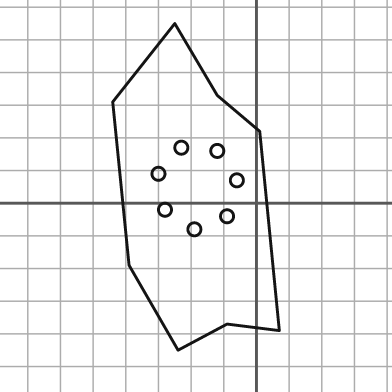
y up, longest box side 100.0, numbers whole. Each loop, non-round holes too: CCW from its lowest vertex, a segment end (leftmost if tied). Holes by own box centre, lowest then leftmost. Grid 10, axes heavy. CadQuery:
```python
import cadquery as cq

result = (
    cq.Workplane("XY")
    .moveTo(-24.0, -45.0)
    .lineTo(-9.0, -37.0)
    .lineTo(7.0, -39.0)
    .lineTo(1.0, 22.0)
    .lineTo(-12.0, 33.0)
    .lineTo(-25.0, 55.0)
    .lineTo(-44.0, 31.0)
    .lineTo(-39.0, -19.0)
    .close()
    .moveTo(-19.0, -8.0)
    .circle(2.0)
    .moveTo(-9.0, -4.0)
    .circle(2.0)
    .moveTo(-28.0, -2.0)
    .circle(2.0)
    .moveTo(-6.0, 7.0)
    .circle(2.0)
    .moveTo(-30.0, 9.0)
    .circle(2.0)
    .moveTo(-12.0, 16.0)
    .circle(2.0)
    .moveTo(-23.0, 17.0)
    .circle(2.0)
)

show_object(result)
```